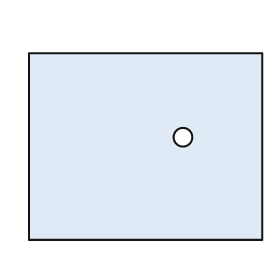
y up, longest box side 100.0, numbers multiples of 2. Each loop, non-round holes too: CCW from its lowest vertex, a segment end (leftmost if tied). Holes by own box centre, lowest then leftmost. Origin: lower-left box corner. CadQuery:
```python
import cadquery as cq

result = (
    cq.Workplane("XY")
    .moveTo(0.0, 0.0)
    .lineTo(100.0, 0.0)
    .lineTo(100.0, 80.0)
    .lineTo(0.0, 80.0)
    .close()
    .moveTo(66.0, 44.0)
    .circle(4.0)
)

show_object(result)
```